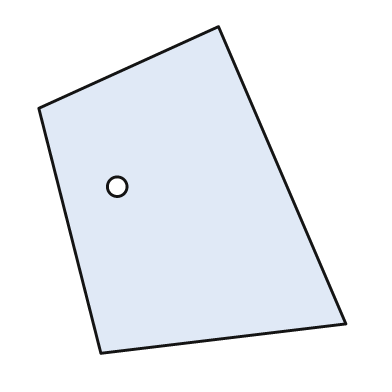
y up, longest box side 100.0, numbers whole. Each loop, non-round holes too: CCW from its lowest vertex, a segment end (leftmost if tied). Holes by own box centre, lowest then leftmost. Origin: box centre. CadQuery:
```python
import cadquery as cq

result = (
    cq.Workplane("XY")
    .moveTo(-28.0, -50.0)
    .lineTo(47.0, -41.0)
    .lineTo(8.0, 50.0)
    .lineTo(-47.0, 25.0)
    .close()
    .moveTo(-23.0, 1.0)
    .circle(3.0)
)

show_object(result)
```